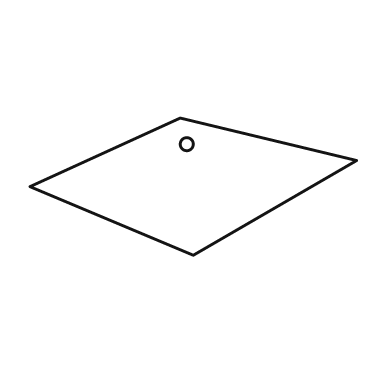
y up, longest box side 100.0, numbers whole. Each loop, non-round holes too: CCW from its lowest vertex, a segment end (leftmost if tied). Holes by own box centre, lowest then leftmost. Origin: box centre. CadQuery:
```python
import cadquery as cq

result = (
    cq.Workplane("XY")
    .moveTo(0.0, -21.0)
    .lineTo(50.0, 8.0)
    .lineTo(-4.0, 21.0)
    .lineTo(-50.0, 0.0)
    .close()
    .moveTo(-2.0, 13.0)
    .circle(2.0)
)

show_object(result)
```